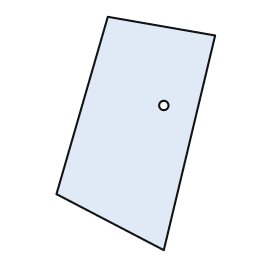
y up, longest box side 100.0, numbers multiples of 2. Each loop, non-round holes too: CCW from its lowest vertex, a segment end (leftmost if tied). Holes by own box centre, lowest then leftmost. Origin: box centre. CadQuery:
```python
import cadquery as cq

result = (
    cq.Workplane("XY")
    .moveTo(12.0, -50.0)
    .lineTo(34.0, 42.0)
    .lineTo(-12.0, 50.0)
    .lineTo(-34.0, -26.0)
    .close()
    .moveTo(12.0, 12.0)
    .circle(2.0)
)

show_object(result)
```